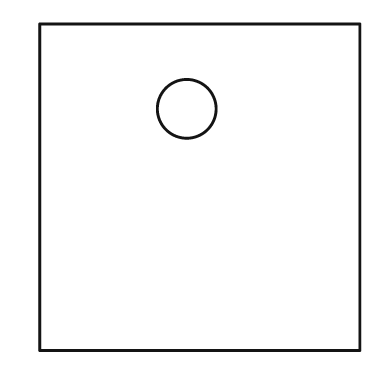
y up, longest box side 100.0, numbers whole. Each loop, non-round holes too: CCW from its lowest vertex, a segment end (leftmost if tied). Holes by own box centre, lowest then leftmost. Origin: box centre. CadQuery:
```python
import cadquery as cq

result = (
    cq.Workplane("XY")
    .moveTo(-49.0, -50.0)
    .lineTo(49.0, -50.0)
    .lineTo(49.0, 50.0)
    .lineTo(-49.0, 50.0)
    .close()
    .moveTo(-4.0, 24.0)
    .circle(9.0)
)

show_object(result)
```